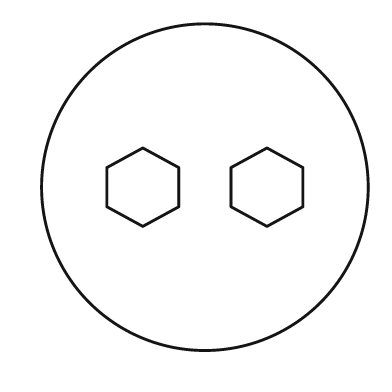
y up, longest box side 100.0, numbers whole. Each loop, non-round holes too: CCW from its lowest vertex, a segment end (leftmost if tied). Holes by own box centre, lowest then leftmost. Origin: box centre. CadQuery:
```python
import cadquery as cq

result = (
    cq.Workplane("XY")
    .moveTo(0.0, 0.0)
    .circle(50.0)
    .moveTo(-19.0, -12.0)
    .lineTo(-8.0, -6.0)
    .lineTo(-8.0, 6.0)
    .lineTo(-19.0, 12.0)
    .lineTo(-30.0, 6.0)
    .lineTo(-30.0, -6.0)
    .close()
    .moveTo(19.0, -12.0)
    .lineTo(30.0, -6.0)
    .lineTo(30.0, 6.0)
    .lineTo(19.0, 12.0)
    .lineTo(8.0, 6.0)
    .lineTo(8.0, -6.0)
    .close()
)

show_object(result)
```